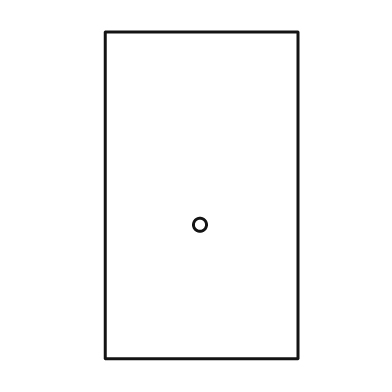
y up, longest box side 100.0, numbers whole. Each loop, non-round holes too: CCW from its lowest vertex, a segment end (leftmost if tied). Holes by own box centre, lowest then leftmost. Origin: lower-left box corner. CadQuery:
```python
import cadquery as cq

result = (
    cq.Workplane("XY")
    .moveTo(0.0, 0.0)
    .lineTo(59.0, 0.0)
    .lineTo(59.0, 100.0)
    .lineTo(0.0, 100.0)
    .close()
    .moveTo(29.0, 41.0)
    .circle(2.0)
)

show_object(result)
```